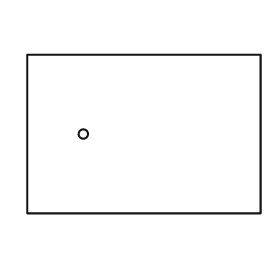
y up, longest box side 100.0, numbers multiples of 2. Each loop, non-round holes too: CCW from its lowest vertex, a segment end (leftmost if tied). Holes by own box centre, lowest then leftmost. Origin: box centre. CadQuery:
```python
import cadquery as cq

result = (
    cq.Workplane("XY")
    .moveTo(-50.0, -34.0)
    .lineTo(50.0, -34.0)
    .lineTo(50.0, 34.0)
    .lineTo(-50.0, 34.0)
    .close()
    .moveTo(-26.0, 0.0)
    .circle(2.0)
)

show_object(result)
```